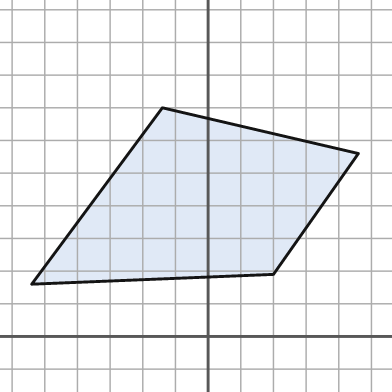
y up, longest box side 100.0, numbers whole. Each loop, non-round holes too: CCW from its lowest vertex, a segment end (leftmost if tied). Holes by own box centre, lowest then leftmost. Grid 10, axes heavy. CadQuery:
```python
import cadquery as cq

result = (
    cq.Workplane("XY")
    .moveTo(-54.0, 16.0)
    .lineTo(20.0, 19.0)
    .lineTo(46.0, 56.0)
    .lineTo(-14.0, 70.0)
    .close()
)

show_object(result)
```